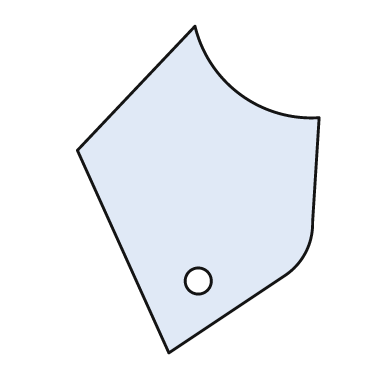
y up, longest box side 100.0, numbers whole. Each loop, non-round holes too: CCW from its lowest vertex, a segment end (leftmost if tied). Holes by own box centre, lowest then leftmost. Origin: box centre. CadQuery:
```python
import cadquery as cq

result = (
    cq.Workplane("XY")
    .moveTo(-9.0, -50.0)
    .lineTo(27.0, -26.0)
    .threePointArc((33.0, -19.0), (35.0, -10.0))
    .lineTo(37.0, 22.0)
    .threePointArc((13.0, 29.0), (-1.0, 50.0))
    .lineTo(-37.0, 12.0)
    .close()
    .moveTo(0.0, -28.0)
    .circle(4.0)
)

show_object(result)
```